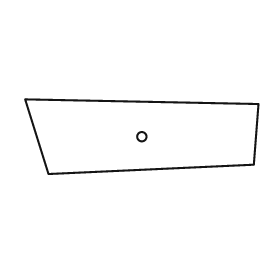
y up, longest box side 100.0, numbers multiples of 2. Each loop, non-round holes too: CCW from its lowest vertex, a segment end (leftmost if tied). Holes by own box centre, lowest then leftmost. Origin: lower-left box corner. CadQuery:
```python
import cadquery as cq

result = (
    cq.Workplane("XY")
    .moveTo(10.0, 0.0)
    .lineTo(98.0, 4.0)
    .lineTo(100.0, 30.0)
    .lineTo(0.0, 32.0)
    .close()
    .moveTo(50.0, 16.0)
    .circle(2.0)
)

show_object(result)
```